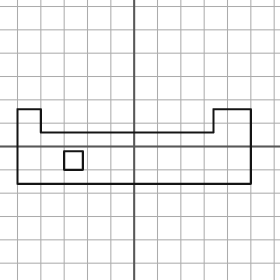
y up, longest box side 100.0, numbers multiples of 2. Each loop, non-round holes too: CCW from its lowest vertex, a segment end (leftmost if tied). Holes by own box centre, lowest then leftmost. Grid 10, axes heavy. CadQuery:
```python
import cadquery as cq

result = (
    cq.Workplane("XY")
    .moveTo(-50.0, -16.0)
    .lineTo(50.0, -16.0)
    .lineTo(50.0, 16.0)
    .lineTo(34.0, 16.0)
    .lineTo(34.0, 6.0)
    .lineTo(-40.0, 6.0)
    .lineTo(-40.0, 16.0)
    .lineTo(-50.0, 16.0)
    .close()
    .moveTo(-30.0, -10.0)
    .lineTo(-22.0, -10.0)
    .lineTo(-22.0, -2.0)
    .lineTo(-30.0, -2.0)
    .close()
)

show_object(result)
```